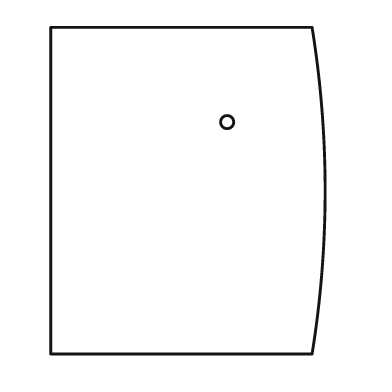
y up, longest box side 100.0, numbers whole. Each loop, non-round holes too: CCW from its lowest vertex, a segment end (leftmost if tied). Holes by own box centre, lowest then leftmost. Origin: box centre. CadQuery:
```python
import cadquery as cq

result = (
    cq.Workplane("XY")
    .moveTo(-42.0, -50.0)
    .lineTo(38.0, -50.0)
    .threePointArc((42.0, 0.0), (38.0, 50.0))
    .lineTo(-42.0, 50.0)
    .close()
    .moveTo(12.0, 21.0)
    .circle(2.0)
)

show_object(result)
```